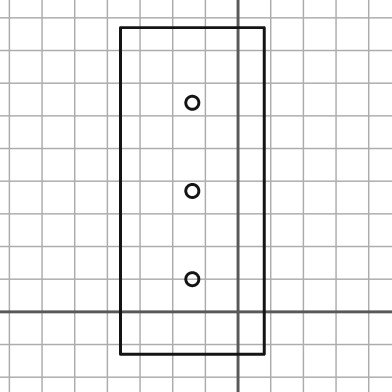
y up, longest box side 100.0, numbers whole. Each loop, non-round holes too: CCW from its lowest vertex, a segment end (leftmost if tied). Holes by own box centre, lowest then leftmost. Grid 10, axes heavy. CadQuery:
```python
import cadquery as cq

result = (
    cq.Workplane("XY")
    .moveTo(-36.0, -13.0)
    .lineTo(8.0, -13.0)
    .lineTo(8.0, 87.0)
    .lineTo(-36.0, 87.0)
    .close()
    .moveTo(-14.0, 10.0)
    .circle(2.0)
    .moveTo(-14.0, 37.0)
    .circle(2.0)
    .moveTo(-14.0, 64.0)
    .circle(2.0)
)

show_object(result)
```